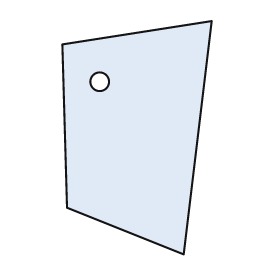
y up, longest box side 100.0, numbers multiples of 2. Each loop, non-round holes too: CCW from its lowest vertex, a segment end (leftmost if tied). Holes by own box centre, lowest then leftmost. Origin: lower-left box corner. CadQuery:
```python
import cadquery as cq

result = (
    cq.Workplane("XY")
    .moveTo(52.0, 0.0)
    .lineTo(64.0, 100.0)
    .lineTo(0.0, 90.0)
    .lineTo(2.0, 20.0)
    .close()
    .moveTo(16.0, 74.0)
    .circle(4.0)
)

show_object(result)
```